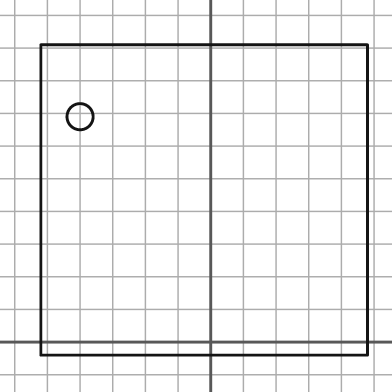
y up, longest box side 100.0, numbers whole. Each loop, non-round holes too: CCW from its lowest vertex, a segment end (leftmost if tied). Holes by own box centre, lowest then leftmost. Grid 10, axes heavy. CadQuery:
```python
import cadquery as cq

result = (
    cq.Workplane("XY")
    .moveTo(-52.0, -4.0)
    .lineTo(48.0, -4.0)
    .lineTo(48.0, 91.0)
    .lineTo(-52.0, 91.0)
    .close()
    .moveTo(-40.0, 69.0)
    .circle(4.0)
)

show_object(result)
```